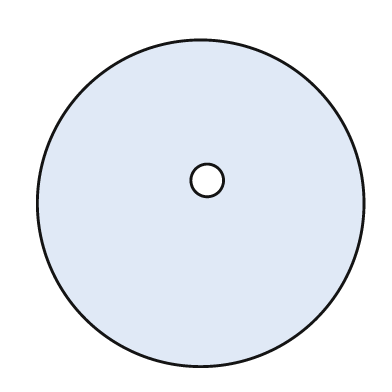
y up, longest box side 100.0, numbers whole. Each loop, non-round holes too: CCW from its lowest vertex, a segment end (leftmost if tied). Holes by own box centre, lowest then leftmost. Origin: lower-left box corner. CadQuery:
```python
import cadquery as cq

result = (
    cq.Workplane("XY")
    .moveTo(50.0, 50.0)
    .circle(50.0)
    .moveTo(52.0, 57.0)
    .circle(5.0)
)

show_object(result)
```